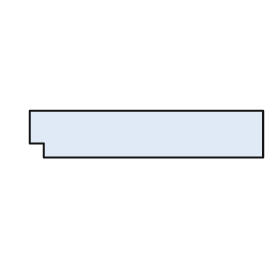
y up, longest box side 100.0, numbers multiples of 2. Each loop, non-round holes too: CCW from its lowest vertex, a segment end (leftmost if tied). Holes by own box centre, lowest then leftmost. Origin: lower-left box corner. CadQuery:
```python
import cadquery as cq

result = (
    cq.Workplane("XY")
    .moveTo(6.0, 0.0)
    .lineTo(100.0, 0.0)
    .lineTo(100.0, 20.0)
    .lineTo(0.0, 20.0)
    .lineTo(0.0, 6.0)
    .lineTo(6.0, 6.0)
    .close()
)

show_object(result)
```